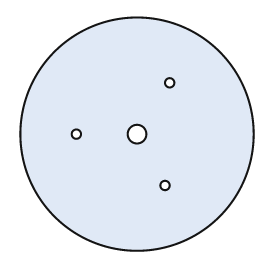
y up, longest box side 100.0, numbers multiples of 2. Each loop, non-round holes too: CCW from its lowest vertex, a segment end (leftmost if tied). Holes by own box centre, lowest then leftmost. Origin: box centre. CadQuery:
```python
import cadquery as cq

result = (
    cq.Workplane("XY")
    .moveTo(0.0, 0.0)
    .circle(50.0)
    .moveTo(12.0, -22.0)
    .circle(2.0)
    .moveTo(-26.0, 0.0)
    .circle(2.0)
    .moveTo(0.0, 0.0)
    .circle(4.0)
    .moveTo(14.0, 22.0)
    .circle(2.0)
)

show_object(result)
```